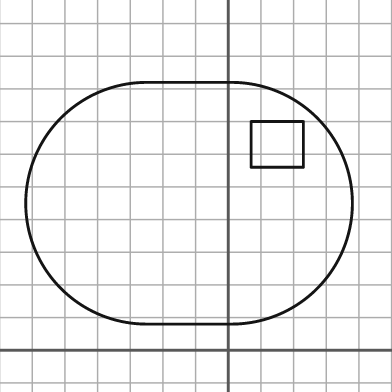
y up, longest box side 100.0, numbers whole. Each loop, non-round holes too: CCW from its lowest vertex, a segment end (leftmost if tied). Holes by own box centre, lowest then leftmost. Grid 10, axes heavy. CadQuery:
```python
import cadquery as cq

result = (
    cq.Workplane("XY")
    .moveTo(-25.0, 8.0)
    .lineTo(1.0, 8.0)
    .threePointArc((38.0, 45.0), (1.0, 82.0))
    .lineTo(-25.0, 82.0)
    .threePointArc((-62.0, 45.0), (-25.0, 8.0))
    .close()
    .moveTo(7.0, 56.0)
    .lineTo(23.0, 56.0)
    .lineTo(23.0, 70.0)
    .lineTo(7.0, 70.0)
    .close()
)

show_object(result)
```